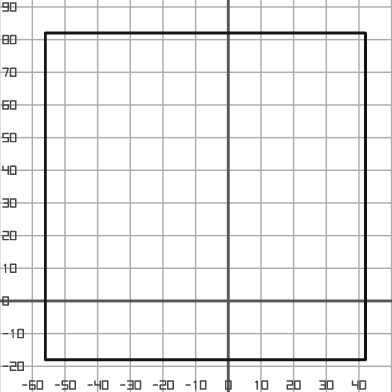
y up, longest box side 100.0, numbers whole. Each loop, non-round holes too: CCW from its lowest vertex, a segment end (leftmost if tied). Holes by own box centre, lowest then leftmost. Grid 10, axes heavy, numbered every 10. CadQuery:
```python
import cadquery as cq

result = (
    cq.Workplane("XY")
    .moveTo(-56.0, -18.0)
    .lineTo(42.0, -18.0)
    .lineTo(42.0, 82.0)
    .lineTo(-56.0, 82.0)
    .close()
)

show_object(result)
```